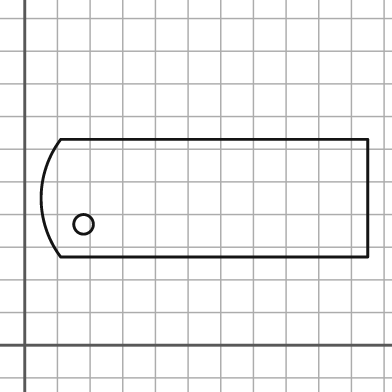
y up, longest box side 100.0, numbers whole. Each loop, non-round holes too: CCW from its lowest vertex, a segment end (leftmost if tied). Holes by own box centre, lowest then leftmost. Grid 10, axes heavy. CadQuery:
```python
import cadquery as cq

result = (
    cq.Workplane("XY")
    .moveTo(11.0, 27.0)
    .lineTo(105.0, 27.0)
    .lineTo(105.0, 63.0)
    .lineTo(11.0, 63.0)
    .threePointArc((5.0, 45.0), (11.0, 27.0))
    .close()
    .moveTo(18.0, 37.0)
    .circle(3.0)
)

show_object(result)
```